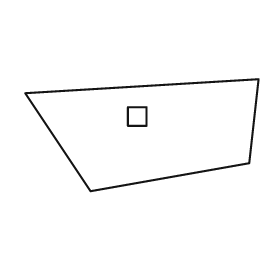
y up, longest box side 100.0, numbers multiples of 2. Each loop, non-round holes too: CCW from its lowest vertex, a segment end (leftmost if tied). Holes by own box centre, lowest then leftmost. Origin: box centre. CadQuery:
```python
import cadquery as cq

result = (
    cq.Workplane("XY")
    .moveTo(-22.0, -24.0)
    .lineTo(46.0, -12.0)
    .lineTo(50.0, 24.0)
    .lineTo(-50.0, 18.0)
    .close()
    .moveTo(-6.0, 4.0)
    .lineTo(2.0, 4.0)
    .lineTo(2.0, 12.0)
    .lineTo(-6.0, 12.0)
    .close()
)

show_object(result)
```